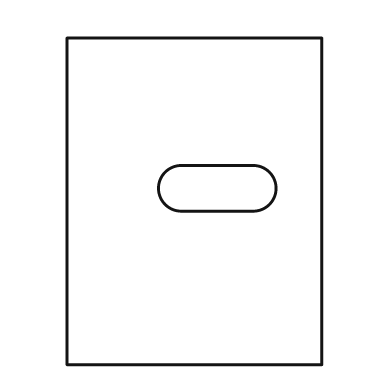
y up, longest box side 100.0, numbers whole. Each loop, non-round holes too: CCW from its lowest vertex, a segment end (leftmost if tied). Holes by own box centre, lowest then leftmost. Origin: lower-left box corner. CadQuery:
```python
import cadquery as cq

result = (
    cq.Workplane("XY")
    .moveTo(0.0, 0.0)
    .lineTo(78.0, 0.0)
    .lineTo(78.0, 100.0)
    .lineTo(0.0, 100.0)
    .close()
    .moveTo(35.0, 47.0)
    .lineTo(57.0, 47.0)
    .threePointArc((64.0, 54.0), (57.0, 61.0))
    .lineTo(35.0, 61.0)
    .threePointArc((28.0, 54.0), (35.0, 47.0))
    .close()
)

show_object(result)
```